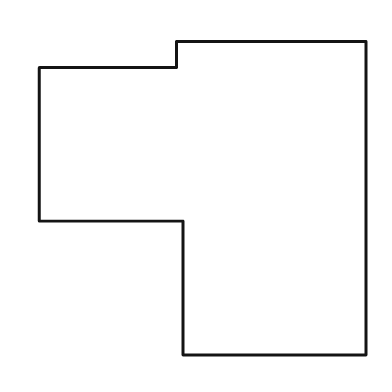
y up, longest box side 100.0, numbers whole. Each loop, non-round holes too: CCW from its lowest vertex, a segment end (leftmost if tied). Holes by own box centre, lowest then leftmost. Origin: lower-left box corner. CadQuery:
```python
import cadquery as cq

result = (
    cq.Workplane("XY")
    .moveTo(44.0, 0.0)
    .lineTo(100.0, 0.0)
    .lineTo(100.0, 96.0)
    .lineTo(42.0, 96.0)
    .lineTo(42.0, 88.0)
    .lineTo(0.0, 88.0)
    .lineTo(0.0, 41.0)
    .lineTo(44.0, 41.0)
    .close()
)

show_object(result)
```